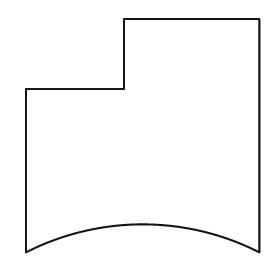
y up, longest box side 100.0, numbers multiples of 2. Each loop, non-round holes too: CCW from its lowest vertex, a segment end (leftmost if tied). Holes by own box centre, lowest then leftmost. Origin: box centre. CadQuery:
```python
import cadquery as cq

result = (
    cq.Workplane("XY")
    .moveTo(-50.0, -50.0)
    .threePointArc((0.0, -38.0), (50.0, -50.0))
    .lineTo(50.0, 50.0)
    .lineTo(-8.0, 50.0)
    .lineTo(-8.0, 20.0)
    .lineTo(-50.0, 20.0)
    .close()
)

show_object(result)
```